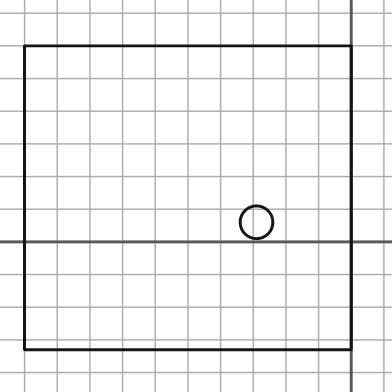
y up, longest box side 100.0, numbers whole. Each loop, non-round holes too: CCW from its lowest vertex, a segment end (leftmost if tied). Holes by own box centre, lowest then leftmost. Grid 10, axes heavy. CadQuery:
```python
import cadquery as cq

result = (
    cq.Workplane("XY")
    .moveTo(-100.0, -33.0)
    .lineTo(0.0, -33.0)
    .lineTo(0.0, 60.0)
    .lineTo(-100.0, 60.0)
    .close()
    .moveTo(-29.0, 6.0)
    .circle(5.0)
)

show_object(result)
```